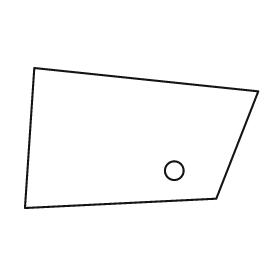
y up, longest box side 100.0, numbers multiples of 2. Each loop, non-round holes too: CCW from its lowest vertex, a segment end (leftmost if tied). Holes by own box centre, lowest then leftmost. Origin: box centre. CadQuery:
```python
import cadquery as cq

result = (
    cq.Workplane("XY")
    .moveTo(-50.0, -30.0)
    .lineTo(32.0, -26.0)
    .lineTo(50.0, 20.0)
    .lineTo(-46.0, 30.0)
    .close()
    .moveTo(14.0, -14.0)
    .circle(4.0)
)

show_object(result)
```